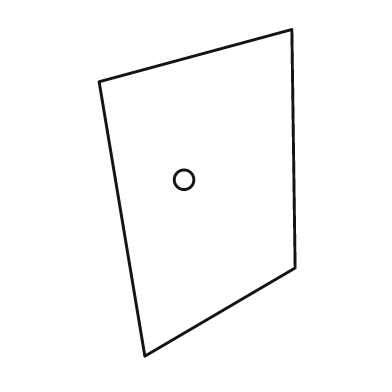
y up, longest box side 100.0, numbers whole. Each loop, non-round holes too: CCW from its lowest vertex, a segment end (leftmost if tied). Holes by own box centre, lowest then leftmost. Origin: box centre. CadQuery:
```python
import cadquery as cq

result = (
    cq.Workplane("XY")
    .moveTo(-16.0, -50.0)
    .lineTo(30.0, -23.0)
    .lineTo(29.0, 50.0)
    .lineTo(-30.0, 34.0)
    .close()
    .moveTo(-4.0, 4.0)
    .circle(3.0)
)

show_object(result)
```